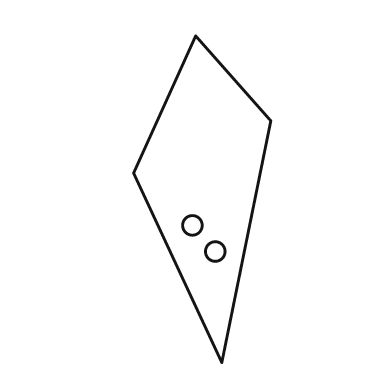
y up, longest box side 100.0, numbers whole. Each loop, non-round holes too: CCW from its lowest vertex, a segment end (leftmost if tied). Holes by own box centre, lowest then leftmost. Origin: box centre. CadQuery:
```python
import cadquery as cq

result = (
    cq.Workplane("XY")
    .moveTo(6.0, -50.0)
    .lineTo(21.0, 24.0)
    .lineTo(-2.0, 50.0)
    .lineTo(-21.0, 8.0)
    .close()
    .moveTo(4.0, -16.0)
    .circle(3.0)
    .moveTo(-3.0, -8.0)
    .circle(3.0)
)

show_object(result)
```